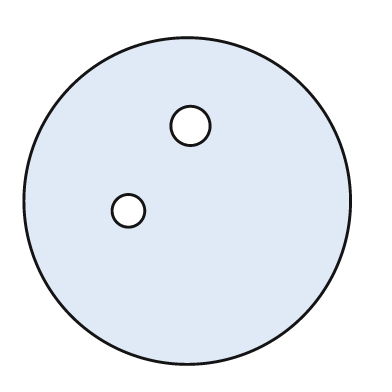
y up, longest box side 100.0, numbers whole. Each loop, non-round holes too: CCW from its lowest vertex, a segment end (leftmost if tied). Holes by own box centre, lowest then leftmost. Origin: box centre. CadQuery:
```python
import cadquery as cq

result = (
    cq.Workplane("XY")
    .moveTo(0.0, 0.0)
    .circle(50.0)
    .moveTo(-18.0, -3.0)
    .circle(5.0)
    .moveTo(1.0, 23.0)
    .circle(6.0)
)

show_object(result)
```